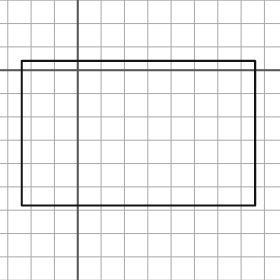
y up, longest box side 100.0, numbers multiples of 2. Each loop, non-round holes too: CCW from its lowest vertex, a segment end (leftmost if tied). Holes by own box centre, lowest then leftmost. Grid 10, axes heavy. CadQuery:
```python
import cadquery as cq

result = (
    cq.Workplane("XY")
    .moveTo(-24.0, -58.0)
    .lineTo(76.0, -58.0)
    .lineTo(76.0, 4.0)
    .lineTo(-24.0, 4.0)
    .close()
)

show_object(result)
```